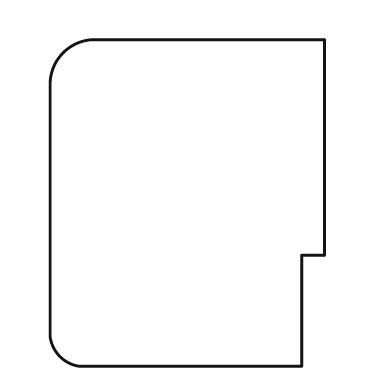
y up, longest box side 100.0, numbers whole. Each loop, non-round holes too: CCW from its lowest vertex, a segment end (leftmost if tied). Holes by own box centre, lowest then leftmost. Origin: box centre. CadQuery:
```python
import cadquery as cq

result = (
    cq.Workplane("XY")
    .moveTo(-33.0, -50.0)
    .lineTo(35.0, -50.0)
    .lineTo(35.0, -16.0)
    .lineTo(42.0, -16.0)
    .lineTo(42.0, 50.0)
    .lineTo(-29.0, 50.0)
    .threePointArc((-38.0, 46.0), (-42.0, 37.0))
    .lineTo(-42.0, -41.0)
    .threePointArc((-39.0, -47.0), (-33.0, -50.0))
    .close()
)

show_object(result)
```